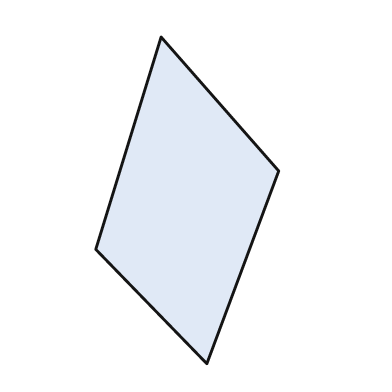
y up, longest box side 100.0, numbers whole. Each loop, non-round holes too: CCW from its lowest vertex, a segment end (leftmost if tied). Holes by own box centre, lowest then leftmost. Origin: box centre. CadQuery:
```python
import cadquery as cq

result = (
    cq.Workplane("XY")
    .moveTo(6.0, -50.0)
    .lineTo(28.0, 9.0)
    .lineTo(-8.0, 50.0)
    .lineTo(-28.0, -15.0)
    .close()
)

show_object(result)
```